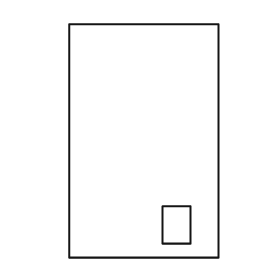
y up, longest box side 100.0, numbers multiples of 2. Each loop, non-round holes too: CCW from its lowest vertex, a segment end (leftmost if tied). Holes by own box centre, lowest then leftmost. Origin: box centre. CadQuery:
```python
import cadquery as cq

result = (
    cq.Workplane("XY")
    .moveTo(-32.0, -50.0)
    .lineTo(32.0, -50.0)
    .lineTo(32.0, 50.0)
    .lineTo(-32.0, 50.0)
    .close()
    .moveTo(8.0, -44.0)
    .lineTo(20.0, -44.0)
    .lineTo(20.0, -28.0)
    .lineTo(8.0, -28.0)
    .close()
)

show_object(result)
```